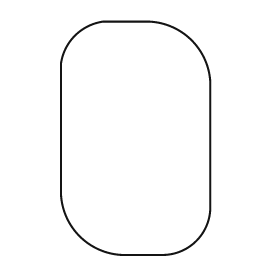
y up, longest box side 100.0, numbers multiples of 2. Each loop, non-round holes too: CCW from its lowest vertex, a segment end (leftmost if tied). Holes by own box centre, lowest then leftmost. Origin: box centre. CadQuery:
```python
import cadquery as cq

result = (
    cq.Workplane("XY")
    .moveTo(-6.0, -50.0)
    .lineTo(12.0, -50.0)
    .threePointArc((26.0, -44.0), (32.0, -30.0))
    .lineTo(32.0, 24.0)
    .threePointArc((24.0, 42.0), (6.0, 50.0))
    .lineTo(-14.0, 50.0)
    .threePointArc((-26.0, 44.0), (-32.0, 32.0))
    .lineTo(-32.0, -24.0)
    .threePointArc((-24.0, -42.0), (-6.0, -50.0))
    .close()
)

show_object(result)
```